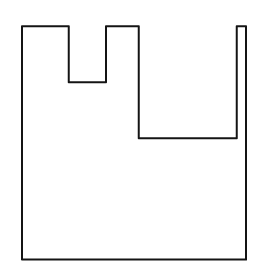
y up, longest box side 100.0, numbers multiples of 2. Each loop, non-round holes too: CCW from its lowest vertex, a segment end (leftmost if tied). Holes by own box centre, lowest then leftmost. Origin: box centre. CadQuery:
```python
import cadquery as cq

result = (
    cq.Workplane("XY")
    .moveTo(-48.0, -50.0)
    .lineTo(48.0, -50.0)
    .lineTo(48.0, 50.0)
    .lineTo(44.0, 50.0)
    .lineTo(44.0, 2.0)
    .lineTo(2.0, 2.0)
    .lineTo(2.0, 50.0)
    .lineTo(-12.0, 50.0)
    .lineTo(-12.0, 26.0)
    .lineTo(-28.0, 26.0)
    .lineTo(-28.0, 50.0)
    .lineTo(-48.0, 50.0)
    .close()
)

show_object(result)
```